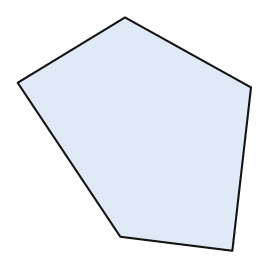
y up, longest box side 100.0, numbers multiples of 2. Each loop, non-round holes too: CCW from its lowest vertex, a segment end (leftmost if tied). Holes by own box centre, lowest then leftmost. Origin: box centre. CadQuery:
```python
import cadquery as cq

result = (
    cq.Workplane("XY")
    .moveTo(42.0, -50.0)
    .lineTo(50.0, 20.0)
    .lineTo(-4.0, 50.0)
    .lineTo(-50.0, 22.0)
    .lineTo(-6.0, -44.0)
    .close()
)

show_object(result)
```